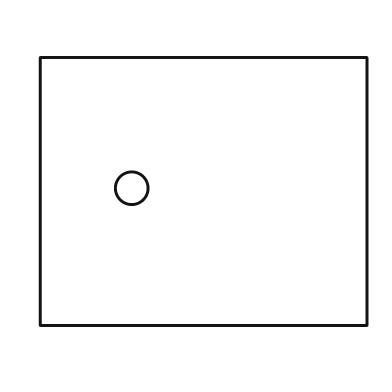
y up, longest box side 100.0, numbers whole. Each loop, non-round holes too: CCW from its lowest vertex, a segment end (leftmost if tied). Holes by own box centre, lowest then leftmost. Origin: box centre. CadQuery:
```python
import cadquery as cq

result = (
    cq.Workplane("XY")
    .moveTo(-50.0, -41.0)
    .lineTo(50.0, -41.0)
    .lineTo(50.0, 41.0)
    .lineTo(-50.0, 41.0)
    .close()
    .moveTo(-22.0, 1.0)
    .circle(5.0)
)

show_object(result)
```